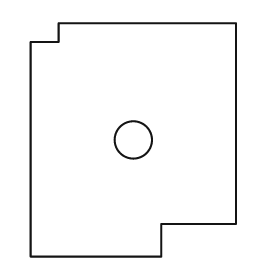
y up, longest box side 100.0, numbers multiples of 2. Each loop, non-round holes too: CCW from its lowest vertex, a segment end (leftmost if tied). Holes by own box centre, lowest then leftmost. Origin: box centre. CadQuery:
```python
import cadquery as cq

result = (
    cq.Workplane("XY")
    .moveTo(-44.0, -50.0)
    .lineTo(12.0, -50.0)
    .lineTo(12.0, -36.0)
    .lineTo(44.0, -36.0)
    .lineTo(44.0, 50.0)
    .lineTo(-32.0, 50.0)
    .lineTo(-32.0, 42.0)
    .lineTo(-44.0, 42.0)
    .close()
    .moveTo(0.0, 0.0)
    .circle(8.0)
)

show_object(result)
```